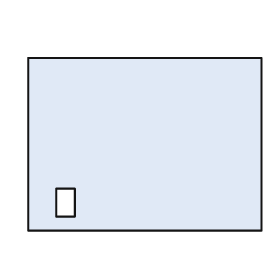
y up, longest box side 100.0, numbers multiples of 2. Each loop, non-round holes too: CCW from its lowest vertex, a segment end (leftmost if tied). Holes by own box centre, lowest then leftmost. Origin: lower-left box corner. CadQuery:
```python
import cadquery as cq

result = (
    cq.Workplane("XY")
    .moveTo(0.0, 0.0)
    .lineTo(100.0, 0.0)
    .lineTo(100.0, 74.0)
    .lineTo(0.0, 74.0)
    .close()
    .moveTo(12.0, 6.0)
    .lineTo(20.0, 6.0)
    .lineTo(20.0, 18.0)
    .lineTo(12.0, 18.0)
    .close()
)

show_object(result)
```